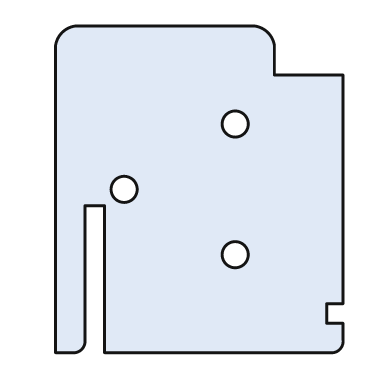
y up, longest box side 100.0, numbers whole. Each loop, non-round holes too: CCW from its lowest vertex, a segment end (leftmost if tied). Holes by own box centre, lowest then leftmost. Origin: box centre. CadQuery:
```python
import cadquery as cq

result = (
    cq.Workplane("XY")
    .moveTo(-44.0, -50.0)
    .lineTo(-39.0, -50.0)
    .threePointArc((-36.0, -49.0), (-35.0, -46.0))
    .lineTo(-35.0, -5.0)
    .lineTo(-29.0, -5.0)
    .lineTo(-29.0, -50.0)
    .lineTo(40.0, -50.0)
    .threePointArc((43.0, -49.0), (44.0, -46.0))
    .lineTo(44.0, -41.0)
    .lineTo(39.0, -41.0)
    .lineTo(39.0, -35.0)
    .lineTo(44.0, -35.0)
    .lineTo(44.0, 35.0)
    .lineTo(23.0, 35.0)
    .lineTo(23.0, 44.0)
    .threePointArc((21.0, 48.0), (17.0, 50.0))
    .lineTo(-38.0, 50.0)
    .threePointArc((-42.0, 48.0), (-44.0, 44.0))
    .close()
    .moveTo(11.0, -20.0)
    .circle(4.0)
    .moveTo(-23.0, 0.0)
    .circle(4.0)
    .moveTo(11.0, 20.0)
    .circle(4.0)
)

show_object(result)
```